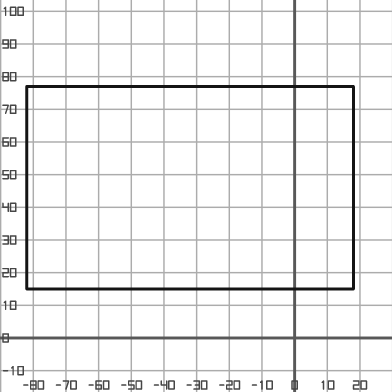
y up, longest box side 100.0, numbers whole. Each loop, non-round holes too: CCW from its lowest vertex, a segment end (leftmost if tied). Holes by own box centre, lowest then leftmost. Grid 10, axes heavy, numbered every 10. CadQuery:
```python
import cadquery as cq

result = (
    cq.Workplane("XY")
    .moveTo(-82.0, 15.0)
    .lineTo(18.0, 15.0)
    .lineTo(18.0, 77.0)
    .lineTo(-82.0, 77.0)
    .close()
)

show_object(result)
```